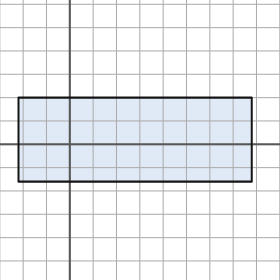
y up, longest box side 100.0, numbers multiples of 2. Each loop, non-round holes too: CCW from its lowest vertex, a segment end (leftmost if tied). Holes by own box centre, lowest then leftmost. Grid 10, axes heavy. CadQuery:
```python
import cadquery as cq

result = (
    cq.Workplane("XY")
    .moveTo(-22.0, -16.0)
    .lineTo(78.0, -16.0)
    .lineTo(78.0, 20.0)
    .lineTo(-22.0, 20.0)
    .close()
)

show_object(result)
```